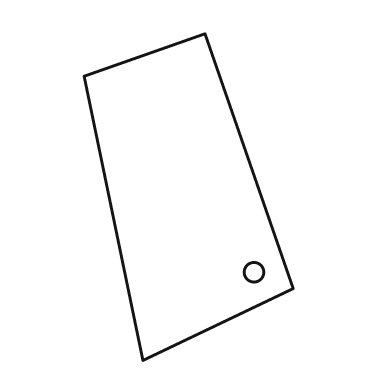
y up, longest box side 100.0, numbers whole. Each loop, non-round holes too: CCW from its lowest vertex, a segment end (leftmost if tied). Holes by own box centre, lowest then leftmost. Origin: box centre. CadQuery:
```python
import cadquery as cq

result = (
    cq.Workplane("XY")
    .moveTo(-14.0, -50.0)
    .lineTo(32.0, -28.0)
    .lineTo(5.0, 50.0)
    .lineTo(-32.0, 37.0)
    .close()
    .moveTo(20.0, -23.0)
    .circle(3.0)
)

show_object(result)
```